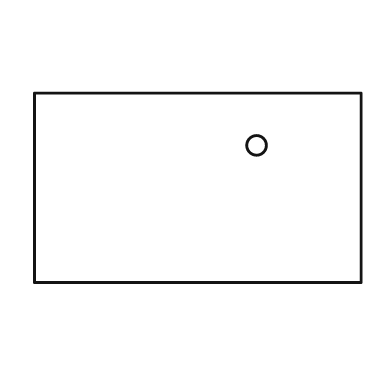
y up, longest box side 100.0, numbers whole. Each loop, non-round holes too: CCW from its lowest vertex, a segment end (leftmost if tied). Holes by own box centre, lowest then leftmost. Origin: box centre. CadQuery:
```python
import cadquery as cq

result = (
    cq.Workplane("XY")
    .moveTo(-50.0, -29.0)
    .lineTo(50.0, -29.0)
    .lineTo(50.0, 29.0)
    .lineTo(-50.0, 29.0)
    .close()
    .moveTo(18.0, 13.0)
    .circle(3.0)
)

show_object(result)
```